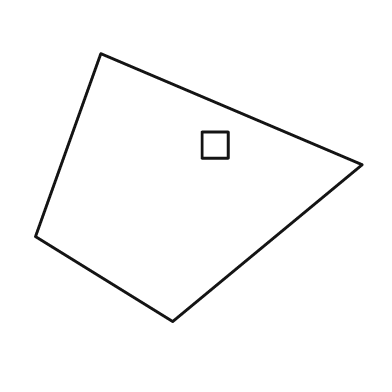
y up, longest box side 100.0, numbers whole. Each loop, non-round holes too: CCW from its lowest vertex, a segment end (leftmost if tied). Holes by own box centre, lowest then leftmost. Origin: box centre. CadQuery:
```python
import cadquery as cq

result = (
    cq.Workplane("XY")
    .moveTo(-8.0, -41.0)
    .lineTo(50.0, 7.0)
    .lineTo(-30.0, 41.0)
    .lineTo(-50.0, -15.0)
    .close()
    .moveTo(1.0, 9.0)
    .lineTo(9.0, 9.0)
    .lineTo(9.0, 17.0)
    .lineTo(1.0, 17.0)
    .close()
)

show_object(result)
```